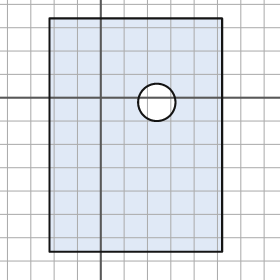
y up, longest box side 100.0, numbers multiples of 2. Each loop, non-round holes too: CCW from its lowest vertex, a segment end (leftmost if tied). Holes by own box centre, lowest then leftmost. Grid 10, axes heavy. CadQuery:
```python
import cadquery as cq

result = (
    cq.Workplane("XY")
    .moveTo(-22.0, -66.0)
    .lineTo(52.0, -66.0)
    .lineTo(52.0, 34.0)
    .lineTo(-22.0, 34.0)
    .close()
    .moveTo(24.0, -2.0)
    .circle(8.0)
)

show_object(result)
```